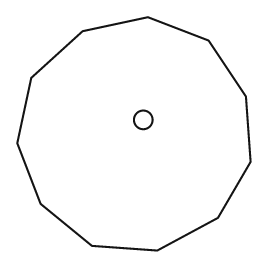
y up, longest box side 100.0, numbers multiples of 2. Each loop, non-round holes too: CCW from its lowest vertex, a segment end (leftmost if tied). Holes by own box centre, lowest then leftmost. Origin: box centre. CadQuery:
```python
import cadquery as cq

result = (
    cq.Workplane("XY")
    .moveTo(10.0, -50.0)
    .lineTo(36.0, -36.0)
    .lineTo(50.0, -12.0)
    .lineTo(48.0, 16.0)
    .lineTo(32.0, 40.0)
    .lineTo(6.0, 50.0)
    .lineTo(-22.0, 44.0)
    .lineTo(-44.0, 24.0)
    .lineTo(-50.0, -4.0)
    .lineTo(-40.0, -30.0)
    .lineTo(-18.0, -48.0)
    .close()
    .moveTo(4.0, 6.0)
    .circle(4.0)
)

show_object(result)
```